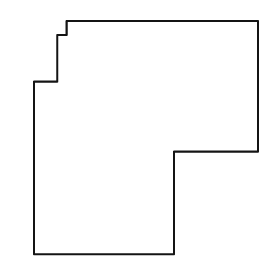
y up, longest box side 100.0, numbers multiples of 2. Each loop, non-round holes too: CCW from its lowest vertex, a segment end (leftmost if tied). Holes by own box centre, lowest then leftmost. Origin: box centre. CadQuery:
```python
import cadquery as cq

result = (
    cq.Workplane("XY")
    .moveTo(-48.0, -50.0)
    .lineTo(12.0, -50.0)
    .lineTo(12.0, -6.0)
    .lineTo(48.0, -6.0)
    .lineTo(48.0, 50.0)
    .lineTo(-34.0, 50.0)
    .lineTo(-34.0, 44.0)
    .lineTo(-38.0, 44.0)
    .lineTo(-38.0, 24.0)
    .lineTo(-48.0, 24.0)
    .close()
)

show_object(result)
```